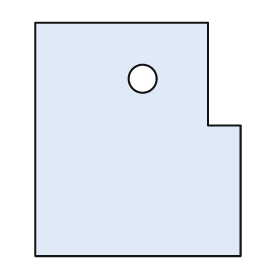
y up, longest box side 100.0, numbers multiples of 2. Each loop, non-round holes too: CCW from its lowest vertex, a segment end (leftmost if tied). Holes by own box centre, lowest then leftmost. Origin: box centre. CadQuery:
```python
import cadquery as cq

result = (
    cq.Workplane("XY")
    .moveTo(-44.0, -50.0)
    .lineTo(44.0, -50.0)
    .lineTo(44.0, 6.0)
    .lineTo(30.0, 6.0)
    .lineTo(30.0, 50.0)
    .lineTo(-44.0, 50.0)
    .close()
    .moveTo(2.0, 26.0)
    .circle(6.0)
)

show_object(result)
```